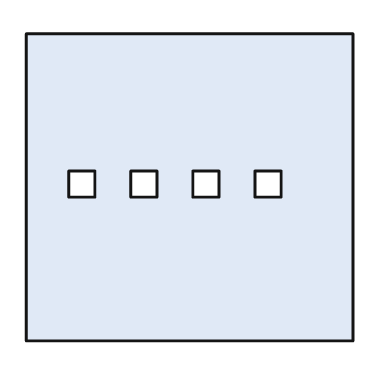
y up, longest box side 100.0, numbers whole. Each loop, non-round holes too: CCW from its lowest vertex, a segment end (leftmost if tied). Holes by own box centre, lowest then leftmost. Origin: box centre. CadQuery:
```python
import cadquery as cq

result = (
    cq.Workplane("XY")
    .moveTo(-50.0, -47.0)
    .lineTo(50.0, -47.0)
    .lineTo(50.0, 47.0)
    .lineTo(-50.0, 47.0)
    .close()
    .moveTo(-37.0, -3.0)
    .lineTo(-29.0, -3.0)
    .lineTo(-29.0, 5.0)
    .lineTo(-37.0, 5.0)
    .close()
    .moveTo(-18.0, -3.0)
    .lineTo(-10.0, -3.0)
    .lineTo(-10.0, 5.0)
    .lineTo(-18.0, 5.0)
    .close()
    .moveTo(1.0, -3.0)
    .lineTo(9.0, -3.0)
    .lineTo(9.0, 5.0)
    .lineTo(1.0, 5.0)
    .close()
    .moveTo(20.0, -3.0)
    .lineTo(28.0, -3.0)
    .lineTo(28.0, 5.0)
    .lineTo(20.0, 5.0)
    .close()
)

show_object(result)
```